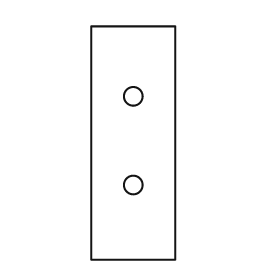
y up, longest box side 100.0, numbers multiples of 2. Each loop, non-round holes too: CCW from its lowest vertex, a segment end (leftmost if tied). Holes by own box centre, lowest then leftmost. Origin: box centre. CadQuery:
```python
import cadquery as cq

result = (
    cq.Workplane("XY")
    .moveTo(-18.0, -50.0)
    .lineTo(18.0, -50.0)
    .lineTo(18.0, 50.0)
    .lineTo(-18.0, 50.0)
    .close()
    .moveTo(0.0, -18.0)
    .circle(4.0)
    .moveTo(0.0, 20.0)
    .circle(4.0)
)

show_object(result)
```